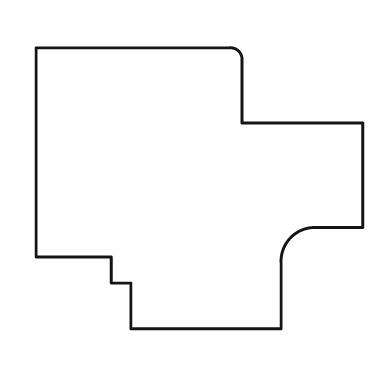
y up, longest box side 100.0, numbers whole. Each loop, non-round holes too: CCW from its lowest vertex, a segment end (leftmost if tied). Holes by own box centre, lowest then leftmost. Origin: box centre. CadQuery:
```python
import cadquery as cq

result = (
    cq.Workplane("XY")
    .moveTo(-21.0, -43.0)
    .lineTo(25.0, -43.0)
    .lineTo(25.0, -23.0)
    .threePointArc((28.0, -15.0), (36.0, -12.0))
    .lineTo(50.0, -12.0)
    .lineTo(50.0, 20.0)
    .lineTo(13.0, 20.0)
    .lineTo(13.0, 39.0)
    .threePointArc((12.0, 42.0), (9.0, 43.0))
    .lineTo(-50.0, 43.0)
    .lineTo(-50.0, -21.0)
    .lineTo(-27.0, -21.0)
    .lineTo(-27.0, -29.0)
    .lineTo(-21.0, -29.0)
    .close()
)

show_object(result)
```